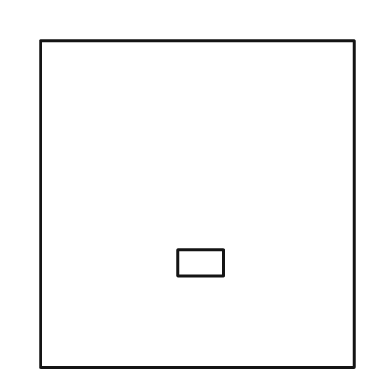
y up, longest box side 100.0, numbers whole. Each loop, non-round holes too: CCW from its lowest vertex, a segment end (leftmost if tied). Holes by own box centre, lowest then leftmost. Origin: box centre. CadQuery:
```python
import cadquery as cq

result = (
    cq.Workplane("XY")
    .moveTo(-48.0, -50.0)
    .lineTo(48.0, -50.0)
    .lineTo(48.0, 50.0)
    .lineTo(-48.0, 50.0)
    .close()
    .moveTo(-6.0, -22.0)
    .lineTo(8.0, -22.0)
    .lineTo(8.0, -14.0)
    .lineTo(-6.0, -14.0)
    .close()
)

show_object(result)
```